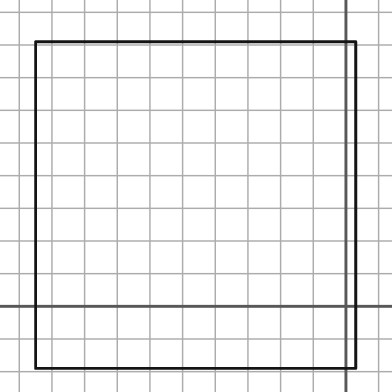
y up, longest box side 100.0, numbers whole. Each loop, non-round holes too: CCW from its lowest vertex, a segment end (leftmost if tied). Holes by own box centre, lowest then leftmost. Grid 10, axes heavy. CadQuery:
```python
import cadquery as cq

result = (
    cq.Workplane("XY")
    .moveTo(-95.0, -19.0)
    .lineTo(3.0, -19.0)
    .lineTo(3.0, 81.0)
    .lineTo(-95.0, 81.0)
    .close()
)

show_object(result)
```